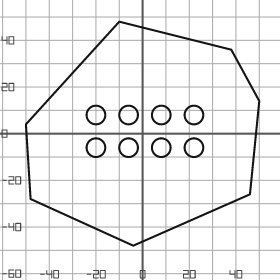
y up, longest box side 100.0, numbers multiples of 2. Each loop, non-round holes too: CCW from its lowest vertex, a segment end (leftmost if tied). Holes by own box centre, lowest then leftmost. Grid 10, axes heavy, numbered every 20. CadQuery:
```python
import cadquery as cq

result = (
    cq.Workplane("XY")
    .moveTo(-4.0, -48.0)
    .lineTo(46.0, -26.0)
    .lineTo(50.0, 14.0)
    .lineTo(38.0, 36.0)
    .lineTo(-10.0, 48.0)
    .lineTo(-50.0, 4.0)
    .lineTo(-48.0, -28.0)
    .close()
    .moveTo(-20.0, -6.0)
    .circle(4.0)
    .moveTo(-6.0, -6.0)
    .circle(4.0)
    .moveTo(8.0, -6.0)
    .circle(4.0)
    .moveTo(22.0, -6.0)
    .circle(4.0)
    .moveTo(-20.0, 8.0)
    .circle(4.0)
    .moveTo(-6.0, 8.0)
    .circle(4.0)
    .moveTo(8.0, 8.0)
    .circle(4.0)
    .moveTo(22.0, 8.0)
    .circle(4.0)
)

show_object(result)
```